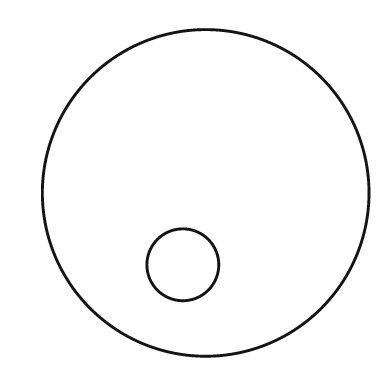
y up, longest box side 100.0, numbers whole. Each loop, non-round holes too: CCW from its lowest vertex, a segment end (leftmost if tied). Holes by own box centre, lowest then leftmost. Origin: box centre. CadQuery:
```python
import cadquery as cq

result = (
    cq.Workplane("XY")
    .moveTo(0.0, 0.0)
    .circle(50.0)
    .moveTo(-7.0, -22.0)
    .circle(11.0)
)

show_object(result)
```